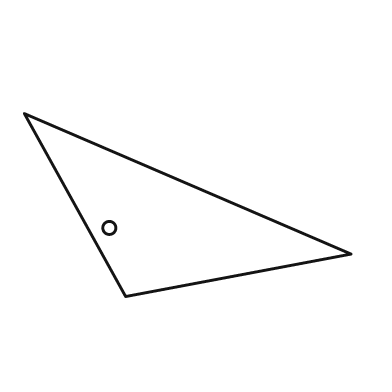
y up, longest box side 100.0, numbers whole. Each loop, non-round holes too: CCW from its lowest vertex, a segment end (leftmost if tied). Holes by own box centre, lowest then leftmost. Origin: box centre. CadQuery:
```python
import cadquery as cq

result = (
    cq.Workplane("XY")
    .moveTo(-19.0, -28.0)
    .lineTo(50.0, -15.0)
    .lineTo(-50.0, 28.0)
    .close()
    .moveTo(-24.0, -7.0)
    .circle(2.0)
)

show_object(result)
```